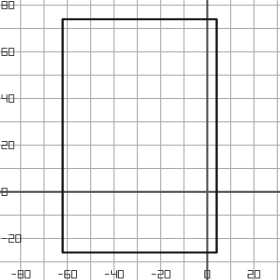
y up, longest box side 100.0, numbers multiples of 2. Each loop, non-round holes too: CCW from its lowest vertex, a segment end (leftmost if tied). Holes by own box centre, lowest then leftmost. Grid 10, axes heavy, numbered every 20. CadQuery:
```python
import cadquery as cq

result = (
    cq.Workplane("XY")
    .moveTo(-62.0, -26.0)
    .lineTo(4.0, -26.0)
    .lineTo(4.0, 74.0)
    .lineTo(-62.0, 74.0)
    .close()
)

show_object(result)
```